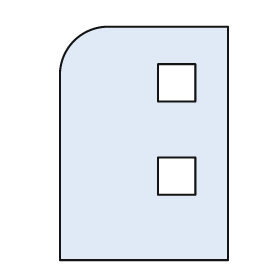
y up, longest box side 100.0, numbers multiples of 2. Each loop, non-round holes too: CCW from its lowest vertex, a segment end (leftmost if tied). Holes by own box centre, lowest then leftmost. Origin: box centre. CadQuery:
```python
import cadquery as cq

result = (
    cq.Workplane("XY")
    .moveTo(-36.0, -50.0)
    .lineTo(36.0, -50.0)
    .lineTo(36.0, 50.0)
    .lineTo(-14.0, 50.0)
    .threePointArc((-30.0, 44.0), (-36.0, 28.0))
    .close()
    .moveTo(6.0, -22.0)
    .lineTo(22.0, -22.0)
    .lineTo(22.0, -6.0)
    .lineTo(6.0, -6.0)
    .close()
    .moveTo(6.0, 18.0)
    .lineTo(22.0, 18.0)
    .lineTo(22.0, 34.0)
    .lineTo(6.0, 34.0)
    .close()
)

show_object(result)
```